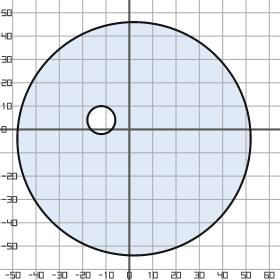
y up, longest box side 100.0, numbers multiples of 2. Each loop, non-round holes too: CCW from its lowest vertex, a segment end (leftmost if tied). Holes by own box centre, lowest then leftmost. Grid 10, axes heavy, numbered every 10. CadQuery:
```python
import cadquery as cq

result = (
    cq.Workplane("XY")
    .moveTo(2.0, -4.0)
    .circle(50.0)
    .moveTo(-12.0, 4.0)
    .circle(6.0)
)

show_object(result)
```